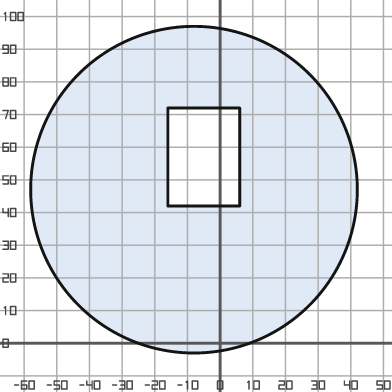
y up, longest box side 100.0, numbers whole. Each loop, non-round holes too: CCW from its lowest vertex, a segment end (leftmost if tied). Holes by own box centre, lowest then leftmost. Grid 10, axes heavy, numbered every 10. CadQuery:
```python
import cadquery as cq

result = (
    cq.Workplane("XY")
    .moveTo(-8.0, 47.0)
    .circle(50.0)
    .moveTo(-16.0, 42.0)
    .lineTo(6.0, 42.0)
    .lineTo(6.0, 72.0)
    .lineTo(-16.0, 72.0)
    .close()
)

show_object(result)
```